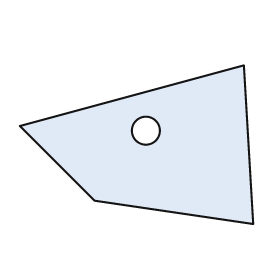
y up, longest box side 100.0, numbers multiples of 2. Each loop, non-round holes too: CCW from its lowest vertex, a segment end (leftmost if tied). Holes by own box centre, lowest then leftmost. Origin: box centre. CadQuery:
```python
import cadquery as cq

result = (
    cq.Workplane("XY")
    .moveTo(50.0, -34.0)
    .lineTo(46.0, 34.0)
    .lineTo(-50.0, 8.0)
    .lineTo(-18.0, -24.0)
    .close()
    .moveTo(4.0, 6.0)
    .circle(6.0)
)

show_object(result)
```